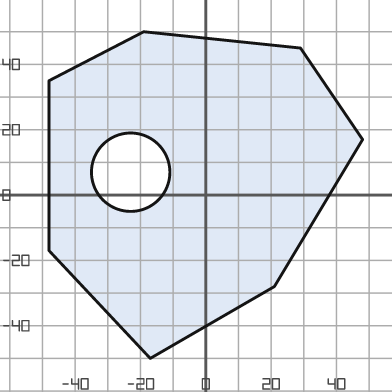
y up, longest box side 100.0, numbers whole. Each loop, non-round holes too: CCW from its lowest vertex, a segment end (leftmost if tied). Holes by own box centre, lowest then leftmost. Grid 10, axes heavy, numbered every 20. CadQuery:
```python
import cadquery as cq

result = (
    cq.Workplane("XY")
    .moveTo(-17.0, -50.0)
    .lineTo(21.0, -28.0)
    .lineTo(48.0, 17.0)
    .lineTo(29.0, 45.0)
    .lineTo(-19.0, 50.0)
    .lineTo(-48.0, 35.0)
    .lineTo(-48.0, -17.0)
    .close()
    .moveTo(-23.0, 7.0)
    .circle(12.0)
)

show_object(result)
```